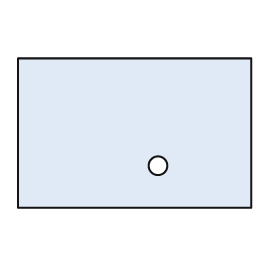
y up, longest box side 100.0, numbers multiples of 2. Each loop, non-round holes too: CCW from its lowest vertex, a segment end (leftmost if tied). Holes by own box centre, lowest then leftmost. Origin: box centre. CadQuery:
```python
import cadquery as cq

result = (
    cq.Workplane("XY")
    .moveTo(-50.0, -32.0)
    .lineTo(50.0, -32.0)
    .lineTo(50.0, 32.0)
    .lineTo(-50.0, 32.0)
    .close()
    .moveTo(10.0, -14.0)
    .circle(4.0)
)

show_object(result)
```